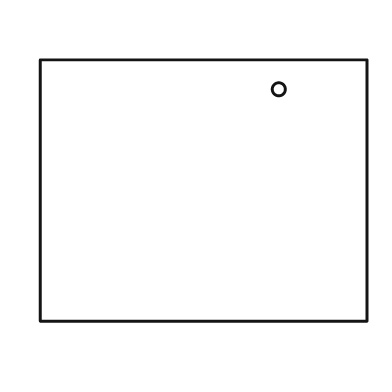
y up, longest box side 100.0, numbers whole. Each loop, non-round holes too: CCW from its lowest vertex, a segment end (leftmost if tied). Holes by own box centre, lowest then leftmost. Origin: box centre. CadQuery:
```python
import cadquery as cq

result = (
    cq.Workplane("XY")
    .moveTo(-50.0, -40.0)
    .lineTo(50.0, -40.0)
    .lineTo(50.0, 40.0)
    .lineTo(-50.0, 40.0)
    .close()
    .moveTo(23.0, 31.0)
    .circle(2.0)
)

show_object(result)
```